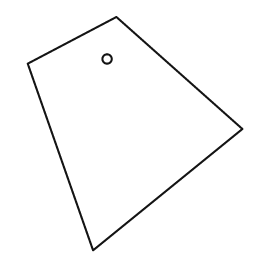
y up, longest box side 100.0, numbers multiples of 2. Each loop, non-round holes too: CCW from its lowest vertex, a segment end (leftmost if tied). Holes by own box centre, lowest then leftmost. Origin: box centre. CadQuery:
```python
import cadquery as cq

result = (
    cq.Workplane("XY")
    .moveTo(-18.0, -50.0)
    .lineTo(46.0, 2.0)
    .lineTo(-8.0, 50.0)
    .lineTo(-46.0, 30.0)
    .close()
    .moveTo(-12.0, 32.0)
    .circle(2.0)
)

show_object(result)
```